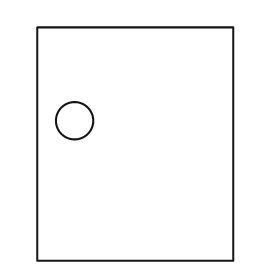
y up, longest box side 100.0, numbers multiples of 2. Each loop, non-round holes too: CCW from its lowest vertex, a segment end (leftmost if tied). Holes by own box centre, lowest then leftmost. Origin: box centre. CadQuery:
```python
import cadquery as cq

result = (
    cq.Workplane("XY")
    .moveTo(-42.0, -50.0)
    .lineTo(42.0, -50.0)
    .lineTo(42.0, 50.0)
    .lineTo(-42.0, 50.0)
    .close()
    .moveTo(-26.0, 10.0)
    .circle(8.0)
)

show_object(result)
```